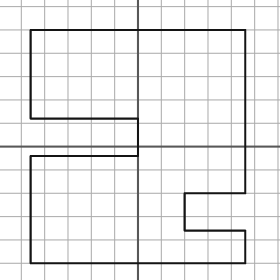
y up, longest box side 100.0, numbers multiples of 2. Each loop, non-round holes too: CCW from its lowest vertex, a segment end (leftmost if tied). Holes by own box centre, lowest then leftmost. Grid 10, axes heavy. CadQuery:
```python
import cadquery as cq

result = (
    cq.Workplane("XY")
    .moveTo(-46.0, -50.0)
    .lineTo(46.0, -50.0)
    .lineTo(46.0, -36.0)
    .lineTo(20.0, -36.0)
    .lineTo(20.0, -20.0)
    .lineTo(46.0, -20.0)
    .lineTo(46.0, 50.0)
    .lineTo(-46.0, 50.0)
    .lineTo(-46.0, 12.0)
    .lineTo(0.0, 12.0)
    .lineTo(0.0, -4.0)
    .lineTo(-46.0, -4.0)
    .close()
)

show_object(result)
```